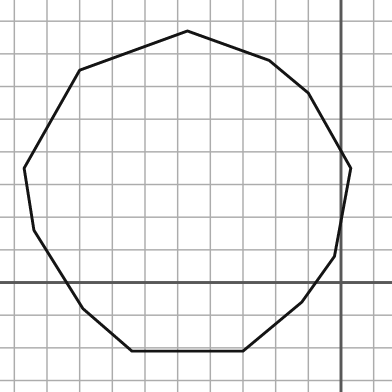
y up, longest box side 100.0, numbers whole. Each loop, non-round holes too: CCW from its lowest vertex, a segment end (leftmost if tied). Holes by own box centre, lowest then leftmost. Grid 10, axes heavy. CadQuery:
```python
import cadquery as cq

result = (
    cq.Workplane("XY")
    .moveTo(-64.0, -21.0)
    .lineTo(-30.0, -21.0)
    .lineTo(-12.0, -6.0)
    .lineTo(-2.0, 8.0)
    .lineTo(3.0, 35.0)
    .lineTo(-10.0, 58.0)
    .lineTo(-22.0, 68.0)
    .lineTo(-47.0, 77.0)
    .lineTo(-80.0, 65.0)
    .lineTo(-97.0, 35.0)
    .lineTo(-94.0, 16.0)
    .lineTo(-79.0, -8.0)
    .close()
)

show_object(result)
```